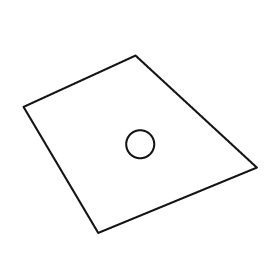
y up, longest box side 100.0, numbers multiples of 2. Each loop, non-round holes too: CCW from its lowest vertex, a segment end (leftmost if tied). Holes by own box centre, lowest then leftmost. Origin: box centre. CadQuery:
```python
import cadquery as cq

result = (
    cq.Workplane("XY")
    .moveTo(-18.0, -38.0)
    .lineTo(50.0, -10.0)
    .lineTo(-2.0, 38.0)
    .lineTo(-50.0, 16.0)
    .close()
    .moveTo(0.0, 0.0)
    .circle(6.0)
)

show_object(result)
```